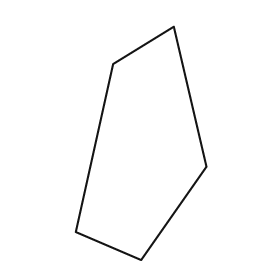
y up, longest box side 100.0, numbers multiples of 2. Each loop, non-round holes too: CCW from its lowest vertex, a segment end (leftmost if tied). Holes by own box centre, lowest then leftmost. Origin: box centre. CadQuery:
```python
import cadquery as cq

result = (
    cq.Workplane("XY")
    .moveTo(0.0, -50.0)
    .lineTo(28.0, -10.0)
    .lineTo(14.0, 50.0)
    .lineTo(-12.0, 34.0)
    .lineTo(-28.0, -38.0)
    .close()
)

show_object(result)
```